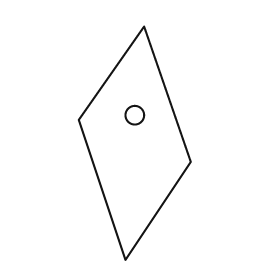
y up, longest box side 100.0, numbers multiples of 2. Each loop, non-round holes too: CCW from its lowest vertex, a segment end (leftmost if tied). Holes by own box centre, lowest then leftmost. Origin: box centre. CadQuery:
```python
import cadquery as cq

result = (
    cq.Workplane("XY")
    .moveTo(-4.0, -50.0)
    .lineTo(24.0, -8.0)
    .lineTo(4.0, 50.0)
    .lineTo(-24.0, 10.0)
    .close()
    .moveTo(0.0, 12.0)
    .circle(4.0)
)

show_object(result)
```